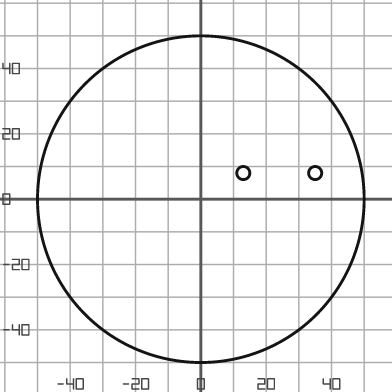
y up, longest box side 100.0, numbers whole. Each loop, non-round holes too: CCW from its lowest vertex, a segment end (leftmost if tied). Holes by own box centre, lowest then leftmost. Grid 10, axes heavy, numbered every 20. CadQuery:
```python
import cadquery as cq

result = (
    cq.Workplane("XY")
    .moveTo(0.0, 0.0)
    .circle(50.0)
    .moveTo(13.0, 8.0)
    .circle(2.0)
    .moveTo(35.0, 8.0)
    .circle(2.0)
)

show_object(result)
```